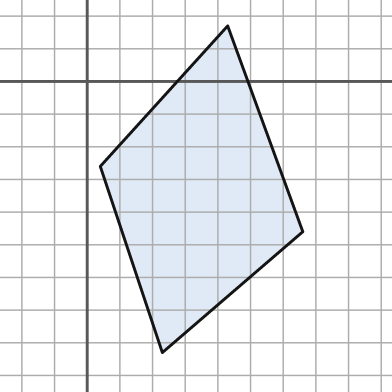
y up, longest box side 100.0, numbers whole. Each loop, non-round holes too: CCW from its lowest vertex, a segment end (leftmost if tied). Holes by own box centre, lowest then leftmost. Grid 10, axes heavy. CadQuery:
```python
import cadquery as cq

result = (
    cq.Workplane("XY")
    .moveTo(23.0, -83.0)
    .lineTo(66.0, -46.0)
    .lineTo(43.0, 17.0)
    .lineTo(4.0, -26.0)
    .close()
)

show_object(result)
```